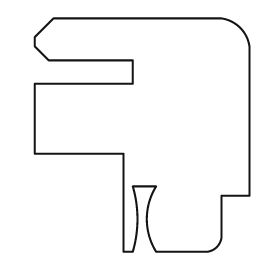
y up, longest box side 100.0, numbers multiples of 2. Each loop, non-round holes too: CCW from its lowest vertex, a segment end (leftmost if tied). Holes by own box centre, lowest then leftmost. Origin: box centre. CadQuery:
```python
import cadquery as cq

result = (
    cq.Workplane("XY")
    .moveTo(-8.0, -50.0)
    .lineTo(-4.0, -50.0)
    .threePointArc((-2.0, -36.0), (-4.0, -22.0))
    .lineTo(6.0, -22.0)
    .threePointArc((2.0, -36.0), (6.0, -50.0))
    .lineTo(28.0, -50.0)
    .threePointArc((32.0, -48.0), (34.0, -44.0))
    .lineTo(34.0, -26.0)
    .lineTo(46.0, -26.0)
    .lineTo(46.0, 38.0)
    .threePointArc((42.0, 46.0), (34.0, 50.0))
    .lineTo(-38.0, 50.0)
    .lineTo(-46.0, 42.0)
    .lineTo(-46.0, 38.0)
    .lineTo(-40.0, 32.0)
    .lineTo(-4.0, 32.0)
    .lineTo(-4.0, 22.0)
    .lineTo(-46.0, 22.0)
    .lineTo(-46.0, -8.0)
    .lineTo(-8.0, -8.0)
    .close()
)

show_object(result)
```